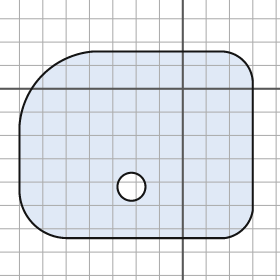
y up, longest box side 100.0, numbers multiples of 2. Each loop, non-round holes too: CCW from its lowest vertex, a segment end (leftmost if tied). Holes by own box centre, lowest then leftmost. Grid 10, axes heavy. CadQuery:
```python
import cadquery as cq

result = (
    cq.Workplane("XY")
    .moveTo(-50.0, -64.0)
    .lineTo(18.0, -64.0)
    .threePointArc((26.0, -60.0), (30.0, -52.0))
    .lineTo(30.0, 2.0)
    .threePointArc((26.0, 12.0), (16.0, 16.0))
    .lineTo(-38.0, 16.0)
    .threePointArc((-60.0, 6.0), (-70.0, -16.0))
    .lineTo(-70.0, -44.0)
    .threePointArc((-64.0, -58.0), (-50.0, -64.0))
    .close()
    .moveTo(-22.0, -42.0)
    .circle(6.0)
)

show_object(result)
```